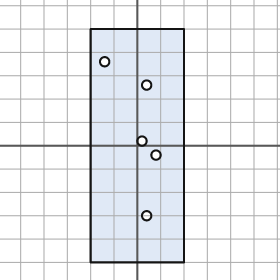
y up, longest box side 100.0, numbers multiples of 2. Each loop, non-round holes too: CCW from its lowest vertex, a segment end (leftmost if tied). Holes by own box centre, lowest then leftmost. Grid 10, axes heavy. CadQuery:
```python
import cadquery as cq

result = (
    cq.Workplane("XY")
    .moveTo(-20.0, -50.0)
    .lineTo(20.0, -50.0)
    .lineTo(20.0, 50.0)
    .lineTo(-20.0, 50.0)
    .close()
    .moveTo(4.0, -30.0)
    .circle(2.0)
    .moveTo(8.0, -4.0)
    .circle(2.0)
    .moveTo(2.0, 2.0)
    .circle(2.0)
    .moveTo(4.0, 26.0)
    .circle(2.0)
    .moveTo(-14.0, 36.0)
    .circle(2.0)
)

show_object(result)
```